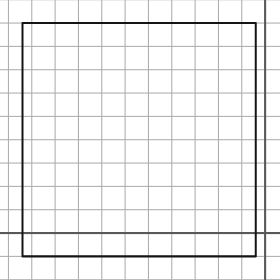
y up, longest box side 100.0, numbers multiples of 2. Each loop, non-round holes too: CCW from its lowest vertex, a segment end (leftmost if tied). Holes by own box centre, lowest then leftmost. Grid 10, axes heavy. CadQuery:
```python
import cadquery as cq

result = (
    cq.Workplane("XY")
    .moveTo(-104.0, -10.0)
    .lineTo(-4.0, -10.0)
    .lineTo(-4.0, 90.0)
    .lineTo(-104.0, 90.0)
    .close()
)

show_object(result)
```